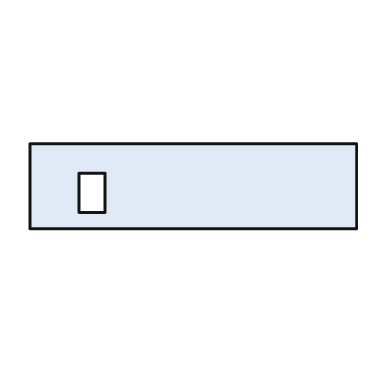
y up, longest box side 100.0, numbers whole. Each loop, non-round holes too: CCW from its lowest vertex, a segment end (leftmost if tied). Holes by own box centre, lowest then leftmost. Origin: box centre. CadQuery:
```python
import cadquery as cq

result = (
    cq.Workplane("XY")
    .moveTo(-50.0, -13.0)
    .lineTo(50.0, -13.0)
    .lineTo(50.0, 13.0)
    .lineTo(-50.0, 13.0)
    .close()
    .moveTo(-35.0, -8.0)
    .lineTo(-27.0, -8.0)
    .lineTo(-27.0, 4.0)
    .lineTo(-35.0, 4.0)
    .close()
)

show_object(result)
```